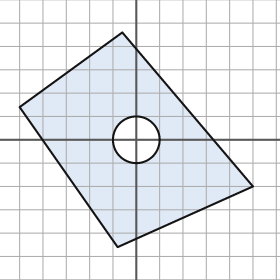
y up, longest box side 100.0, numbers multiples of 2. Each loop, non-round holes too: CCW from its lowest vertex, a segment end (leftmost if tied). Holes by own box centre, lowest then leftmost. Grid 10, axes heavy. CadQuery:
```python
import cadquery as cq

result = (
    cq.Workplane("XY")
    .moveTo(-8.0, -46.0)
    .lineTo(50.0, -20.0)
    .lineTo(-6.0, 46.0)
    .lineTo(-50.0, 14.0)
    .close()
    .moveTo(0.0, 0.0)
    .circle(10.0)
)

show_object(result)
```